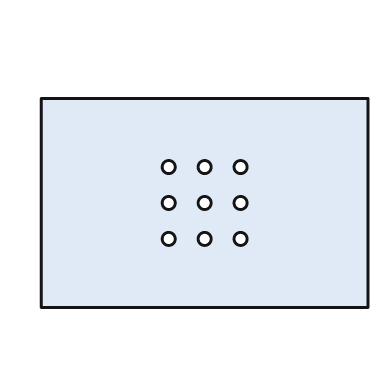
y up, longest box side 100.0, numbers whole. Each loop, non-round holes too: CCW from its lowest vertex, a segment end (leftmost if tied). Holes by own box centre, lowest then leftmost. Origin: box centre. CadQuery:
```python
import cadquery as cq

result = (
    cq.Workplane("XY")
    .moveTo(-50.0, -32.0)
    .lineTo(50.0, -32.0)
    .lineTo(50.0, 32.0)
    .lineTo(-50.0, 32.0)
    .close()
    .moveTo(-11.0, -11.0)
    .circle(2.0)
    .moveTo(0.0, -11.0)
    .circle(2.0)
    .moveTo(11.0, -11.0)
    .circle(2.0)
    .moveTo(-11.0, 0.0)
    .circle(2.0)
    .moveTo(0.0, 0.0)
    .circle(2.0)
    .moveTo(11.0, 0.0)
    .circle(2.0)
    .moveTo(-11.0, 11.0)
    .circle(2.0)
    .moveTo(0.0, 11.0)
    .circle(2.0)
    .moveTo(11.0, 11.0)
    .circle(2.0)
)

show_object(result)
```